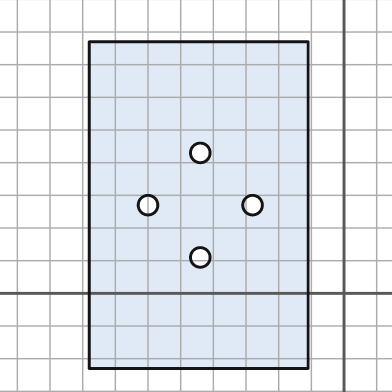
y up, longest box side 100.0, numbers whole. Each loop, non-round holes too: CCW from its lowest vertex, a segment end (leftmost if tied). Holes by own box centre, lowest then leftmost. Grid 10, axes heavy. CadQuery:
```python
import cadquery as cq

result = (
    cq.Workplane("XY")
    .moveTo(-78.0, -23.0)
    .lineTo(-11.0, -23.0)
    .lineTo(-11.0, 77.0)
    .lineTo(-78.0, 77.0)
    .close()
    .moveTo(-44.0, 11.0)
    .circle(3.0)
    .moveTo(-60.0, 27.0)
    .circle(3.0)
    .moveTo(-28.0, 27.0)
    .circle(3.0)
    .moveTo(-44.0, 43.0)
    .circle(3.0)
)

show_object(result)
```